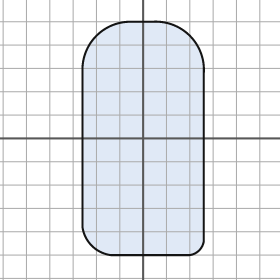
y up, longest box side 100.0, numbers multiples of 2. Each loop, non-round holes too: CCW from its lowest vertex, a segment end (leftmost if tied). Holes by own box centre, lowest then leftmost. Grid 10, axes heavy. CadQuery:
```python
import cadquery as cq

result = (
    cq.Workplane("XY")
    .moveTo(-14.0, -50.0)
    .lineTo(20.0, -50.0)
    .threePointArc((24.0, -48.0), (26.0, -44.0))
    .lineTo(26.0, 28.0)
    .threePointArc((20.0, 44.0), (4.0, 50.0))
    .lineTo(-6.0, 50.0)
    .threePointArc((-20.0, 44.0), (-26.0, 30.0))
    .lineTo(-26.0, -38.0)
    .threePointArc((-22.0, -46.0), (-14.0, -50.0))
    .close()
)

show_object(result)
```